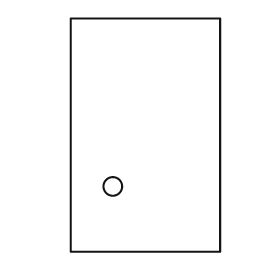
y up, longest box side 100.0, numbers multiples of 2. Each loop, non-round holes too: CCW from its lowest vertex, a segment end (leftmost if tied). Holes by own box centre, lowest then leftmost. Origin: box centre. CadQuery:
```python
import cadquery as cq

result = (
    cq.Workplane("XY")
    .moveTo(-32.0, -50.0)
    .lineTo(32.0, -50.0)
    .lineTo(32.0, 50.0)
    .lineTo(-32.0, 50.0)
    .close()
    .moveTo(-14.0, -22.0)
    .circle(4.0)
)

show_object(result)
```